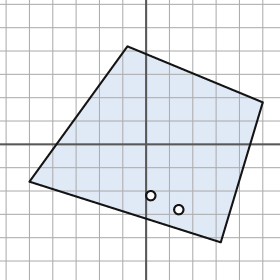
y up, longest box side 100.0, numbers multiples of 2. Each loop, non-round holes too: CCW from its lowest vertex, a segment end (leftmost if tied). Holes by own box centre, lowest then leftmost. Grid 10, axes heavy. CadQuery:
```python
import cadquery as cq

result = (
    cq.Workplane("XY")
    .moveTo(32.0, -42.0)
    .lineTo(50.0, 18.0)
    .lineTo(-8.0, 42.0)
    .lineTo(-50.0, -16.0)
    .close()
    .moveTo(14.0, -28.0)
    .circle(2.0)
    .moveTo(2.0, -22.0)
    .circle(2.0)
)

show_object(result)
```